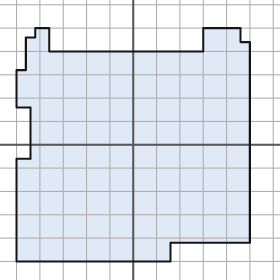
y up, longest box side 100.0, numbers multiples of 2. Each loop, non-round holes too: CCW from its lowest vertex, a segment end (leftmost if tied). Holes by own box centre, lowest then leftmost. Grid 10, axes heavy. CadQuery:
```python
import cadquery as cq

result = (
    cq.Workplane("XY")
    .moveTo(-50.0, -50.0)
    .lineTo(16.0, -50.0)
    .lineTo(16.0, -42.0)
    .lineTo(50.0, -42.0)
    .lineTo(50.0, 44.0)
    .lineTo(46.0, 44.0)
    .lineTo(46.0, 50.0)
    .lineTo(30.0, 50.0)
    .lineTo(30.0, 40.0)
    .lineTo(-36.0, 40.0)
    .lineTo(-36.0, 50.0)
    .lineTo(-42.0, 50.0)
    .lineTo(-42.0, 46.0)
    .lineTo(-46.0, 46.0)
    .lineTo(-46.0, 32.0)
    .lineTo(-50.0, 32.0)
    .lineTo(-50.0, 16.0)
    .lineTo(-44.0, 16.0)
    .lineTo(-44.0, -6.0)
    .lineTo(-50.0, -6.0)
    .close()
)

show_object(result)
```